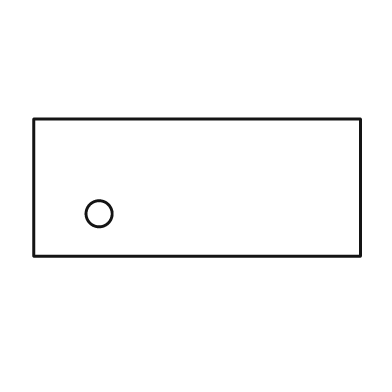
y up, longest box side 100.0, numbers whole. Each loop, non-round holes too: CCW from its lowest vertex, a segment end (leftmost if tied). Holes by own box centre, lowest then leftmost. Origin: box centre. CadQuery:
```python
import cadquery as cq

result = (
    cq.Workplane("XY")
    .moveTo(-50.0, -21.0)
    .lineTo(50.0, -21.0)
    .lineTo(50.0, 21.0)
    .lineTo(-50.0, 21.0)
    .close()
    .moveTo(-30.0, -8.0)
    .circle(4.0)
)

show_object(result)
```